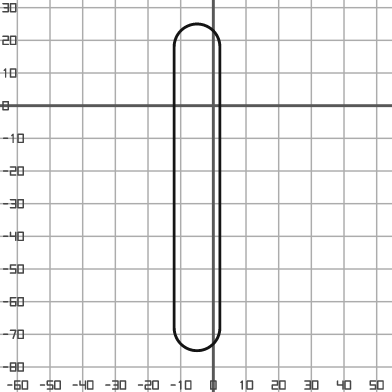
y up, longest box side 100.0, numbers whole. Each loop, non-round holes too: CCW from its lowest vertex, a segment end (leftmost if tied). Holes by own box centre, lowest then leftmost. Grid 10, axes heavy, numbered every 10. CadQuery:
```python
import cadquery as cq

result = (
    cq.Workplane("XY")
    .moveTo(-12.0, -68.0)
    .threePointArc((-5.0, -75.0), (2.0, -68.0))
    .lineTo(2.0, 18.0)
    .threePointArc((-5.0, 25.0), (-12.0, 18.0))
    .close()
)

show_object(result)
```